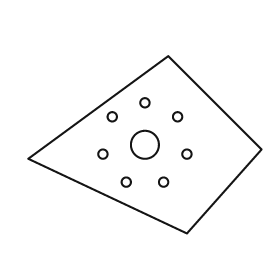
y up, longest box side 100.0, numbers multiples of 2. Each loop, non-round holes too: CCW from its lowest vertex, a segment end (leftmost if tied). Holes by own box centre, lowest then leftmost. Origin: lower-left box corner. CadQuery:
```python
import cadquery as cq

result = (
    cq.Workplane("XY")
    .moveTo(68.0, 0.0)
    .lineTo(100.0, 36.0)
    .lineTo(60.0, 76.0)
    .lineTo(0.0, 32.0)
    .close()
    .moveTo(42.0, 22.0)
    .circle(2.0)
    .moveTo(58.0, 22.0)
    .circle(2.0)
    .moveTo(32.0, 34.0)
    .circle(2.0)
    .moveTo(68.0, 34.0)
    .circle(2.0)
    .moveTo(50.0, 38.0)
    .circle(6.0)
    .moveTo(36.0, 50.0)
    .circle(2.0)
    .moveTo(64.0, 50.0)
    .circle(2.0)
    .moveTo(50.0, 56.0)
    .circle(2.0)
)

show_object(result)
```